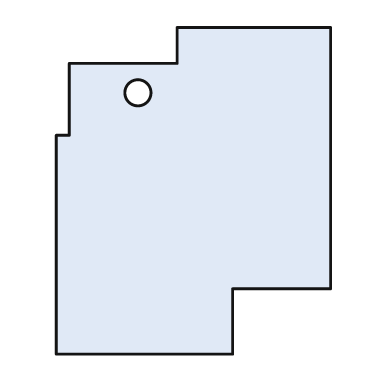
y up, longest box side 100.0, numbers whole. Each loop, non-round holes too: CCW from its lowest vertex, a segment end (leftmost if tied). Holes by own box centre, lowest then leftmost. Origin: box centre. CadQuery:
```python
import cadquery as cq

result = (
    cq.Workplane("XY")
    .moveTo(-42.0, -50.0)
    .lineTo(12.0, -50.0)
    .lineTo(12.0, -30.0)
    .lineTo(42.0, -30.0)
    .lineTo(42.0, 50.0)
    .lineTo(-5.0, 50.0)
    .lineTo(-5.0, 39.0)
    .lineTo(-38.0, 39.0)
    .lineTo(-38.0, 17.0)
    .lineTo(-42.0, 17.0)
    .close()
    .moveTo(-17.0, 30.0)
    .circle(4.0)
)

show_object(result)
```